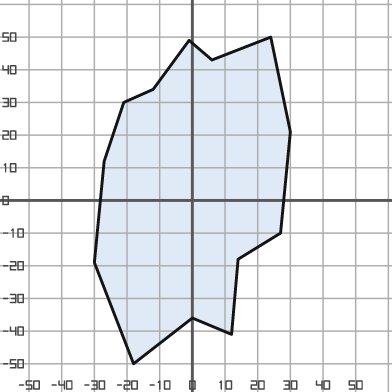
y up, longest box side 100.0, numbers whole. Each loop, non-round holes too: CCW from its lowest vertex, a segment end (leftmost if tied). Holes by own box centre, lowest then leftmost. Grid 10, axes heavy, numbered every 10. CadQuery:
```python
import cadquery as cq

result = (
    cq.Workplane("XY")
    .moveTo(-18.0, -50.0)
    .lineTo(0.0, -36.0)
    .lineTo(12.0, -41.0)
    .lineTo(14.0, -18.0)
    .lineTo(27.0, -10.0)
    .lineTo(30.0, 21.0)
    .lineTo(24.0, 50.0)
    .lineTo(6.0, 43.0)
    .lineTo(-1.0, 49.0)
    .lineTo(-12.0, 34.0)
    .lineTo(-21.0, 30.0)
    .lineTo(-27.0, 12.0)
    .lineTo(-30.0, -19.0)
    .close()
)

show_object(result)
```